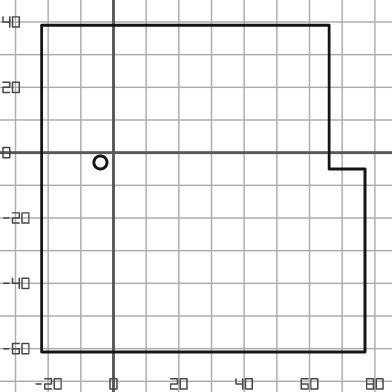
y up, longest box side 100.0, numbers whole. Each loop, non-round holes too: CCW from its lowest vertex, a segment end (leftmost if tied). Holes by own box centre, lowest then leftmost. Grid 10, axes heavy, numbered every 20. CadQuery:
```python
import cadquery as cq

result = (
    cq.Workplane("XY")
    .moveTo(-22.0, -61.0)
    .lineTo(77.0, -61.0)
    .lineTo(77.0, -5.0)
    .lineTo(66.0, -5.0)
    .lineTo(66.0, 39.0)
    .lineTo(-22.0, 39.0)
    .close()
    .moveTo(-4.0, -3.0)
    .circle(2.0)
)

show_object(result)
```